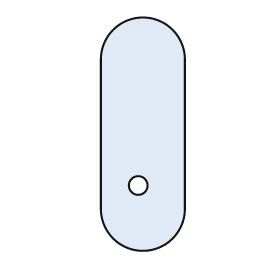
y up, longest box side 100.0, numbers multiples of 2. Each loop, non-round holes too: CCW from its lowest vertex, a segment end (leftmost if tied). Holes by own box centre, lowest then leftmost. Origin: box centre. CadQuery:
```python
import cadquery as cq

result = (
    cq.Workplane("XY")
    .moveTo(-18.0, -32.0)
    .threePointArc((0.0, -50.0), (18.0, -32.0))
    .lineTo(18.0, 32.0)
    .threePointArc((0.0, 50.0), (-18.0, 32.0))
    .close()
    .moveTo(-2.0, -22.0)
    .circle(4.0)
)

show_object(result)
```